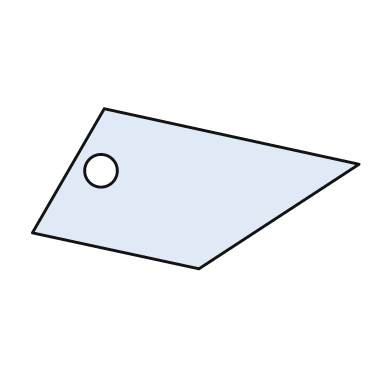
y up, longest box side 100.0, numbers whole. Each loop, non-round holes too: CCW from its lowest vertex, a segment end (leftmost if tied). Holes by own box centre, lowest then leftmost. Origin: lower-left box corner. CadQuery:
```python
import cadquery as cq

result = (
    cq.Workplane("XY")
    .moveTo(51.0, 0.0)
    .lineTo(100.0, 32.0)
    .lineTo(22.0, 49.0)
    .lineTo(0.0, 11.0)
    .close()
    .moveTo(21.0, 30.0)
    .circle(5.0)
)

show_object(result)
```